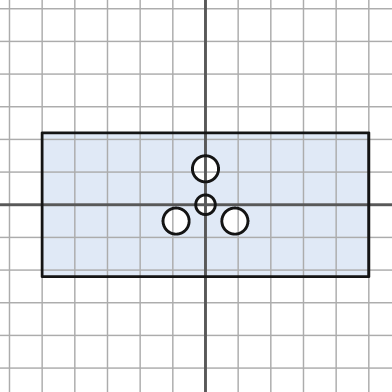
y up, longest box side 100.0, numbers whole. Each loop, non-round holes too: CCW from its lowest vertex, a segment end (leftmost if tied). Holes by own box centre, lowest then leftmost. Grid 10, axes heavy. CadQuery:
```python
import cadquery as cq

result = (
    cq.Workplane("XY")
    .moveTo(-50.0, -22.0)
    .lineTo(50.0, -22.0)
    .lineTo(50.0, 22.0)
    .lineTo(-50.0, 22.0)
    .close()
    .moveTo(-9.0, -5.0)
    .circle(4.0)
    .moveTo(9.0, -5.0)
    .circle(4.0)
    .moveTo(0.0, 0.0)
    .circle(3.0)
    .moveTo(0.0, 11.0)
    .circle(4.0)
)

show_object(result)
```